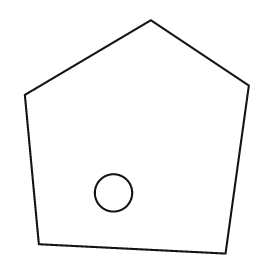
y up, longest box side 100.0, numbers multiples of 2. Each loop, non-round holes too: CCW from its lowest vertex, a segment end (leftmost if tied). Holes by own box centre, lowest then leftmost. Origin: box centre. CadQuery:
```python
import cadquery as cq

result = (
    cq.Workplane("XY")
    .moveTo(38.0, -50.0)
    .lineTo(48.0, 22.0)
    .lineTo(6.0, 50.0)
    .lineTo(-48.0, 18.0)
    .lineTo(-42.0, -46.0)
    .close()
    .moveTo(-10.0, -24.0)
    .circle(8.0)
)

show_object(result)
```